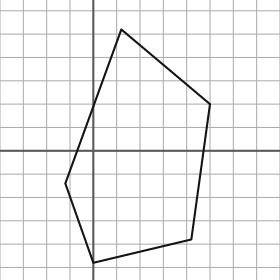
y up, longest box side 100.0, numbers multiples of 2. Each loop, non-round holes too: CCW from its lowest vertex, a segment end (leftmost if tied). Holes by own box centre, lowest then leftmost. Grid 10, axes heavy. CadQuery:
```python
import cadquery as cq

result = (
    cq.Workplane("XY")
    .moveTo(0.0, -48.0)
    .lineTo(42.0, -38.0)
    .lineTo(50.0, 20.0)
    .lineTo(12.0, 52.0)
    .lineTo(-12.0, -14.0)
    .close()
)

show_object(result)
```